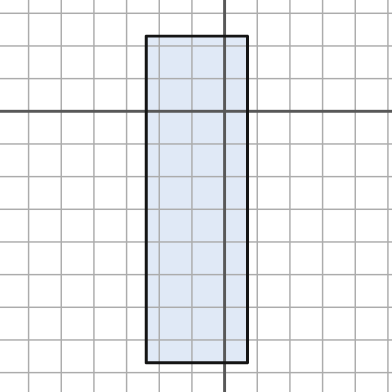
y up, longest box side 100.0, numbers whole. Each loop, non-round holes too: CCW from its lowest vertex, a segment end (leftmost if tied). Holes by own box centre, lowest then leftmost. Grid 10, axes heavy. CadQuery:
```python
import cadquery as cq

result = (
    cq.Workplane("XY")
    .moveTo(-24.0, -77.0)
    .lineTo(7.0, -77.0)
    .lineTo(7.0, 23.0)
    .lineTo(-24.0, 23.0)
    .close()
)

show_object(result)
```